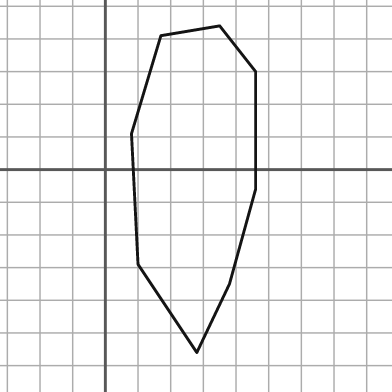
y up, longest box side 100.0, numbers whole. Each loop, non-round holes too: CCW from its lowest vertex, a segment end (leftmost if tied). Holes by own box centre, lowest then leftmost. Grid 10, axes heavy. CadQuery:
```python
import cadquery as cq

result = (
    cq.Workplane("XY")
    .moveTo(28.0, -56.0)
    .lineTo(38.0, -35.0)
    .lineTo(46.0, -6.0)
    .lineTo(46.0, 30.0)
    .lineTo(35.0, 44.0)
    .lineTo(17.0, 41.0)
    .lineTo(8.0, 11.0)
    .lineTo(10.0, -29.0)
    .close()
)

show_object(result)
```